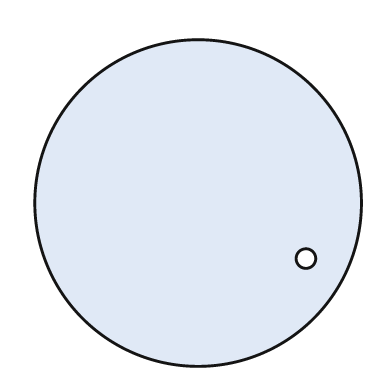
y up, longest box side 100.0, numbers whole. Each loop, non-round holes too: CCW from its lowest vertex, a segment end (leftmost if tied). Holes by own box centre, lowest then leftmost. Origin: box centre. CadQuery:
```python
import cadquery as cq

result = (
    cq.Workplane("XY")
    .moveTo(0.0, 0.0)
    .circle(50.0)
    .moveTo(33.0, -17.0)
    .circle(3.0)
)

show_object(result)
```